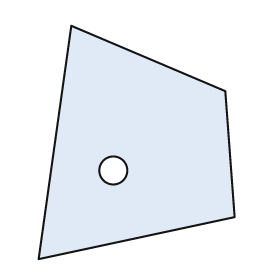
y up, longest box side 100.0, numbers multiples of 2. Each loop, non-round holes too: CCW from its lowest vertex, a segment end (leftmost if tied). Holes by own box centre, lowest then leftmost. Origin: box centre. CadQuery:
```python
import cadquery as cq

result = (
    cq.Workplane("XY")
    .moveTo(-42.0, -50.0)
    .lineTo(42.0, -32.0)
    .lineTo(38.0, 22.0)
    .lineTo(-28.0, 50.0)
    .close()
    .moveTo(-10.0, -12.0)
    .circle(6.0)
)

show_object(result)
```